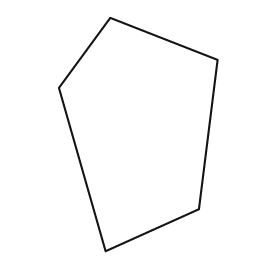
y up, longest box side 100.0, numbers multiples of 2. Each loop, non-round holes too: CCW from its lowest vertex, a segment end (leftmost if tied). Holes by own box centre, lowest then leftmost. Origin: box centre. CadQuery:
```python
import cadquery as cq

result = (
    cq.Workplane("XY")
    .moveTo(-14.0, -50.0)
    .lineTo(26.0, -32.0)
    .lineTo(34.0, 32.0)
    .lineTo(-12.0, 50.0)
    .lineTo(-34.0, 20.0)
    .close()
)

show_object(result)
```